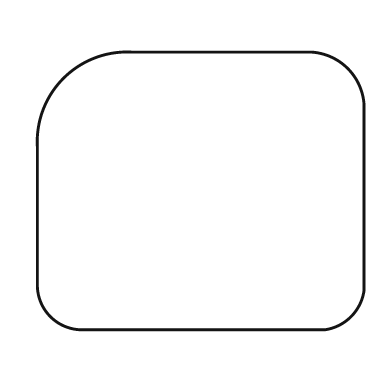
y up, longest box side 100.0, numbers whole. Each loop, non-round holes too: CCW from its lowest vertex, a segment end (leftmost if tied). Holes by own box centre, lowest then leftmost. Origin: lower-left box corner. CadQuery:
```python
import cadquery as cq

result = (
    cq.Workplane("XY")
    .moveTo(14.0, 0.0)
    .lineTo(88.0, 0.0)
    .threePointArc((96.0, 4.0), (100.0, 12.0))
    .lineTo(100.0, 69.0)
    .threePointArc((95.0, 80.0), (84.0, 85.0))
    .lineTo(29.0, 85.0)
    .threePointArc((8.0, 77.0), (0.0, 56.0))
    .lineTo(0.0, 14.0)
    .threePointArc((4.0, 4.0), (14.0, 0.0))
    .close()
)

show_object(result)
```